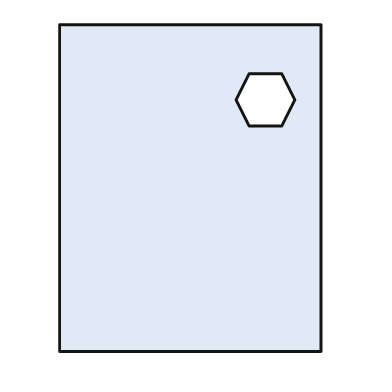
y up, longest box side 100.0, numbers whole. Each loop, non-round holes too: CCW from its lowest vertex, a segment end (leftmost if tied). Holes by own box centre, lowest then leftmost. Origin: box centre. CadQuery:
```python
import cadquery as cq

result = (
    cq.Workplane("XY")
    .moveTo(-40.0, -50.0)
    .lineTo(40.0, -50.0)
    .lineTo(40.0, 50.0)
    .lineTo(-40.0, 50.0)
    .close()
    .moveTo(18.0, 19.0)
    .lineTo(28.0, 19.0)
    .lineTo(32.0, 27.0)
    .lineTo(28.0, 35.0)
    .lineTo(18.0, 35.0)
    .lineTo(14.0, 27.0)
    .close()
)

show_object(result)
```